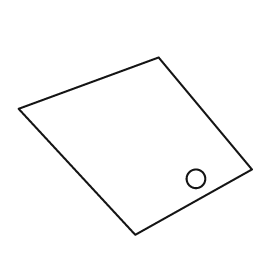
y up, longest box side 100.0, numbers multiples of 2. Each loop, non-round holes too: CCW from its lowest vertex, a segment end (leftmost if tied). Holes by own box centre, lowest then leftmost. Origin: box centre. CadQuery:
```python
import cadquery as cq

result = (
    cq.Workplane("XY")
    .moveTo(0.0, -38.0)
    .lineTo(50.0, -10.0)
    .lineTo(10.0, 38.0)
    .lineTo(-50.0, 16.0)
    .close()
    .moveTo(26.0, -14.0)
    .circle(4.0)
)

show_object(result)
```